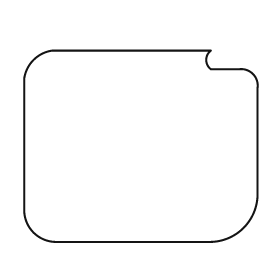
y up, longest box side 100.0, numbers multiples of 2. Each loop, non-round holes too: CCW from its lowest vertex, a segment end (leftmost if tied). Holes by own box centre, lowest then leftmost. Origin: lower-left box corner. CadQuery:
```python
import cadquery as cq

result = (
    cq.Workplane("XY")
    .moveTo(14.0, 0.0)
    .lineTo(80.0, 0.0)
    .threePointArc((94.0, 6.0), (100.0, 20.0))
    .lineTo(100.0, 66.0)
    .threePointArc((98.0, 72.0), (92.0, 74.0))
    .lineTo(80.0, 74.0)
    .threePointArc((78.0, 78.0), (80.0, 82.0))
    .lineTo(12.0, 82.0)
    .threePointArc((4.0, 78.0), (0.0, 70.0))
    .lineTo(0.0, 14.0)
    .threePointArc((4.0, 4.0), (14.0, 0.0))
    .close()
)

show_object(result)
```